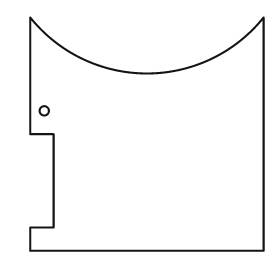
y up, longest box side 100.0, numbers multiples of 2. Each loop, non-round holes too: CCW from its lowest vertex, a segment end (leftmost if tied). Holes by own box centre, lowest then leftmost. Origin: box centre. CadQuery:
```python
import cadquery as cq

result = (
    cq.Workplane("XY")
    .moveTo(-50.0, -50.0)
    .lineTo(50.0, -50.0)
    .lineTo(50.0, 50.0)
    .threePointArc((0.0, 26.0), (-50.0, 50.0))
    .lineTo(-50.0, 0.0)
    .lineTo(-40.0, 0.0)
    .lineTo(-40.0, -40.0)
    .lineTo(-50.0, -40.0)
    .close()
    .moveTo(-44.0, 10.0)
    .circle(2.0)
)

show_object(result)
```